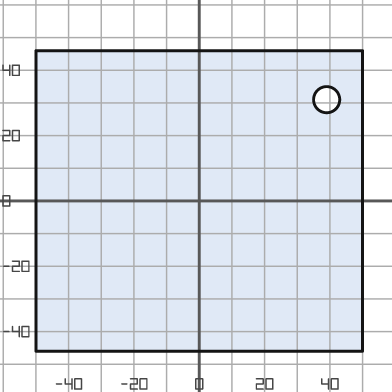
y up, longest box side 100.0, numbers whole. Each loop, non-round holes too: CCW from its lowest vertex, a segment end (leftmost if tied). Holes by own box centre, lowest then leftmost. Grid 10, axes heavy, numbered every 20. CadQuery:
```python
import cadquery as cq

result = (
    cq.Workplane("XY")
    .moveTo(-50.0, -46.0)
    .lineTo(50.0, -46.0)
    .lineTo(50.0, 46.0)
    .lineTo(-50.0, 46.0)
    .close()
    .moveTo(39.0, 31.0)
    .circle(4.0)
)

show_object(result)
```